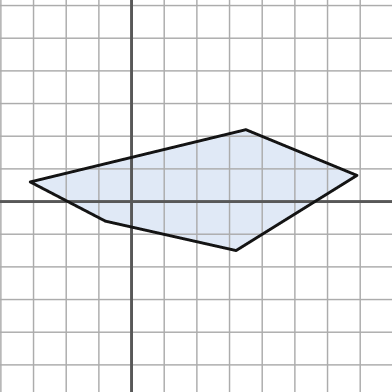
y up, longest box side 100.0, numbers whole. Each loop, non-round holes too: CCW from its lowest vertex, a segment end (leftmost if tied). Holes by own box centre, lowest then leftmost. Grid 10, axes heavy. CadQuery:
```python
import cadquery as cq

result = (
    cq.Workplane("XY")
    .moveTo(32.0, -15.0)
    .lineTo(69.0, 8.0)
    .lineTo(35.0, 22.0)
    .lineTo(-31.0, 6.0)
    .lineTo(-8.0, -6.0)
    .close()
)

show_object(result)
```